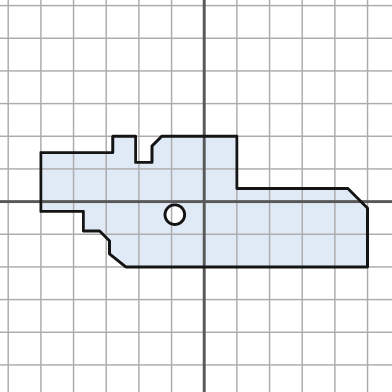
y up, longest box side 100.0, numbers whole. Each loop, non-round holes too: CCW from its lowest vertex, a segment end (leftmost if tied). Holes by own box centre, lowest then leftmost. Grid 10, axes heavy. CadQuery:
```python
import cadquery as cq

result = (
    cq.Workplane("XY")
    .moveTo(-24.0, -20.0)
    .lineTo(50.0, -20.0)
    .lineTo(50.0, -2.0)
    .lineTo(44.0, 4.0)
    .lineTo(10.0, 4.0)
    .lineTo(10.0, 20.0)
    .lineTo(-13.0, 20.0)
    .lineTo(-16.0, 17.0)
    .lineTo(-16.0, 12.0)
    .lineTo(-21.0, 12.0)
    .lineTo(-21.0, 20.0)
    .lineTo(-28.0, 20.0)
    .lineTo(-28.0, 15.0)
    .lineTo(-50.0, 15.0)
    .lineTo(-50.0, -3.0)
    .lineTo(-37.0, -3.0)
    .lineTo(-37.0, -9.0)
    .lineTo(-32.0, -9.0)
    .lineTo(-29.0, -12.0)
    .lineTo(-29.0, -16.0)
    .close()
    .moveTo(-9.0, -4.0)
    .circle(3.0)
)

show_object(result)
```